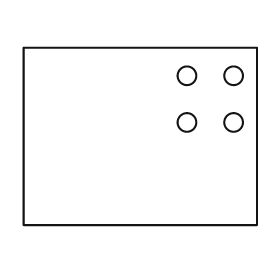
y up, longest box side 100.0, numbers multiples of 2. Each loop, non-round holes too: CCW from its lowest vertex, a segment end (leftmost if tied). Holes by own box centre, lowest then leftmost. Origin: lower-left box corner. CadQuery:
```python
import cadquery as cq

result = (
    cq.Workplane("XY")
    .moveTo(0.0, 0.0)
    .lineTo(100.0, 0.0)
    .lineTo(100.0, 76.0)
    .lineTo(0.0, 76.0)
    .close()
    .moveTo(70.0, 44.0)
    .circle(4.0)
    .moveTo(90.0, 44.0)
    .circle(4.0)
    .moveTo(70.0, 64.0)
    .circle(4.0)
    .moveTo(90.0, 64.0)
    .circle(4.0)
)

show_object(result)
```